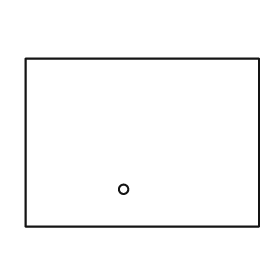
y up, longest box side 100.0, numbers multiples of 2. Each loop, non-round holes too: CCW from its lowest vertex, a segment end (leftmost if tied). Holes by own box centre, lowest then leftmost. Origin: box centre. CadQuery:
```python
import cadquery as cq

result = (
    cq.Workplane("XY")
    .moveTo(-50.0, -36.0)
    .lineTo(50.0, -36.0)
    .lineTo(50.0, 36.0)
    .lineTo(-50.0, 36.0)
    .close()
    .moveTo(-8.0, -20.0)
    .circle(2.0)
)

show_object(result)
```